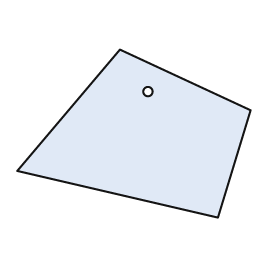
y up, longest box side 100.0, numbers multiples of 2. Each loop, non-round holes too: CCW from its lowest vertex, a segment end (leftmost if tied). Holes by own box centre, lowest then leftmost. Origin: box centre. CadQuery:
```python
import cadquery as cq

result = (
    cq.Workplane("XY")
    .moveTo(36.0, -36.0)
    .lineTo(50.0, 10.0)
    .lineTo(-6.0, 36.0)
    .lineTo(-50.0, -16.0)
    .close()
    .moveTo(6.0, 18.0)
    .circle(2.0)
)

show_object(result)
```